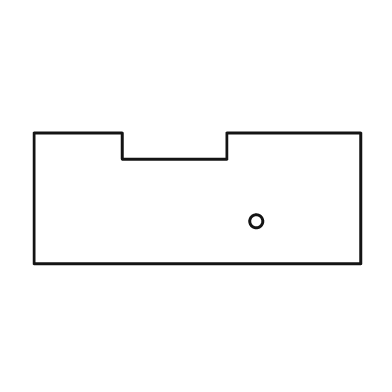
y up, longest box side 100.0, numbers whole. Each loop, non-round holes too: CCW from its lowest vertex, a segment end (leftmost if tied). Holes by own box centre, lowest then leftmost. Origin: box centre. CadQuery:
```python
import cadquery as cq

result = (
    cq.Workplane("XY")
    .moveTo(-50.0, -20.0)
    .lineTo(50.0, -20.0)
    .lineTo(50.0, 20.0)
    .lineTo(9.0, 20.0)
    .lineTo(9.0, 12.0)
    .lineTo(-23.0, 12.0)
    .lineTo(-23.0, 20.0)
    .lineTo(-50.0, 20.0)
    .close()
    .moveTo(18.0, -7.0)
    .circle(2.0)
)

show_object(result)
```